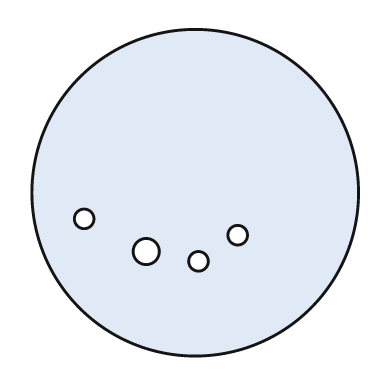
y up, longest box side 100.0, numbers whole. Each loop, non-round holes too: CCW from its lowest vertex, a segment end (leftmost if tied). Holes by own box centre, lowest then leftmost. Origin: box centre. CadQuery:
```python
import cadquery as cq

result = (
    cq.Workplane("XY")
    .moveTo(0.0, 0.0)
    .circle(50.0)
    .moveTo(1.0, -21.0)
    .circle(3.0)
    .moveTo(-15.0, -18.0)
    .circle(4.0)
    .moveTo(13.0, -13.0)
    .circle(3.0)
    .moveTo(-34.0, -8.0)
    .circle(3.0)
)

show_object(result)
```